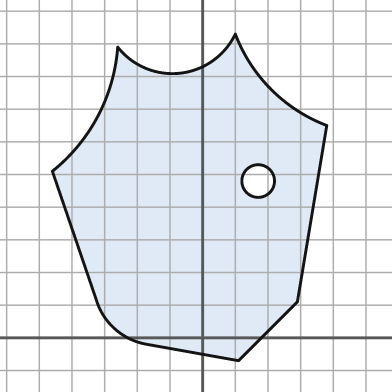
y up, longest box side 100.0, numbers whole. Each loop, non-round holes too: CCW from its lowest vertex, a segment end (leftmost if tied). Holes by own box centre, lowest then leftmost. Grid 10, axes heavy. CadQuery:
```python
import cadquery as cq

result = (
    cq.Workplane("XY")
    .moveTo(11.0, -7.0)
    .lineTo(29.0, 11.0)
    .lineTo(38.0, 65.0)
    .threePointArc((21.0, 76.0), (10.0, 93.0))
    .threePointArc((-7.0, 81.0), (-26.0, 89.0))
    .threePointArc((-32.0, 68.0), (-46.0, 51.0))
    .lineTo(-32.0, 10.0)
    .threePointArc((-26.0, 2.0), (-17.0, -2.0))
    .close()
    .moveTo(17.0, 48.0)
    .circle(5.0)
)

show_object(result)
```